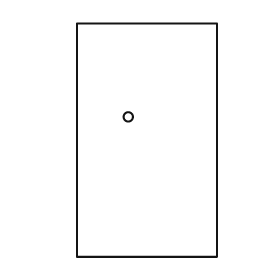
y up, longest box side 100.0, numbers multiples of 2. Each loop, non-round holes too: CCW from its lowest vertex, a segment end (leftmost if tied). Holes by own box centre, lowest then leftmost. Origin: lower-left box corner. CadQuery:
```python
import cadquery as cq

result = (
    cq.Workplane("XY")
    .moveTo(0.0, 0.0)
    .lineTo(60.0, 0.0)
    .lineTo(60.0, 100.0)
    .lineTo(0.0, 100.0)
    .close()
    .moveTo(22.0, 60.0)
    .circle(2.0)
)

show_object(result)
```